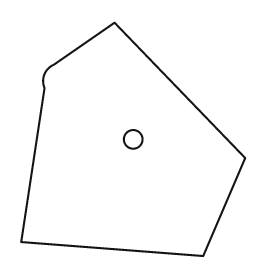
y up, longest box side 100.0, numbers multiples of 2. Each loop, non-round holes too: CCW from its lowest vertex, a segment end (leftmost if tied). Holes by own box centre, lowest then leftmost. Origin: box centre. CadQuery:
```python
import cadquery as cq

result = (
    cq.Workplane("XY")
    .moveTo(30.0, -50.0)
    .lineTo(48.0, -8.0)
    .lineTo(-8.0, 50.0)
    .lineTo(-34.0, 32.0)
    .threePointArc((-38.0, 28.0), (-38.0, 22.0))
    .lineTo(-48.0, -44.0)
    .close()
    .moveTo(0.0, 0.0)
    .circle(4.0)
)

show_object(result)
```